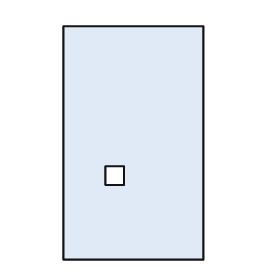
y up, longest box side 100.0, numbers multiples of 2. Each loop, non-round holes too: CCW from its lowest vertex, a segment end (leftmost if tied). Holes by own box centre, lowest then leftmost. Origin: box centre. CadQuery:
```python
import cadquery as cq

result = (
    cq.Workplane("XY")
    .moveTo(-30.0, -50.0)
    .lineTo(30.0, -50.0)
    .lineTo(30.0, 50.0)
    .lineTo(-30.0, 50.0)
    .close()
    .moveTo(-12.0, -18.0)
    .lineTo(-4.0, -18.0)
    .lineTo(-4.0, -10.0)
    .lineTo(-12.0, -10.0)
    .close()
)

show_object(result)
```